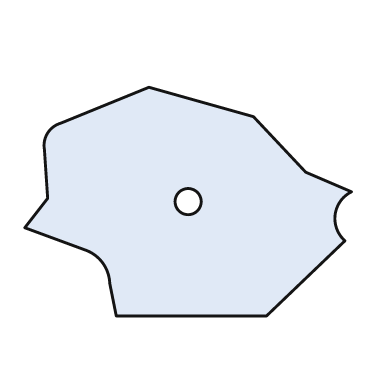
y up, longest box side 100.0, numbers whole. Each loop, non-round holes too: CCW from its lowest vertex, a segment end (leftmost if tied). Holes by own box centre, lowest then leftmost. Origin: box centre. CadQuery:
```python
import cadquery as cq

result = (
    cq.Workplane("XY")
    .moveTo(-22.0, -35.0)
    .lineTo(24.0, -35.0)
    .lineTo(48.0, -12.0)
    .threePointArc((45.0, -4.0), (50.0, 3.0))
    .lineTo(36.0, 9.0)
    .lineTo(20.0, 26.0)
    .lineTo(-12.0, 35.0)
    .lineTo(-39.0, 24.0)
    .threePointArc((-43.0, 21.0), (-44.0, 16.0))
    .lineTo(-43.0, 1.0)
    .lineTo(-50.0, -8.0)
    .lineTo(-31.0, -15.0)
    .threePointArc((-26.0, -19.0), (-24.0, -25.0))
    .close()
    .moveTo(0.0, 0.0)
    .circle(4.0)
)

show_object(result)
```